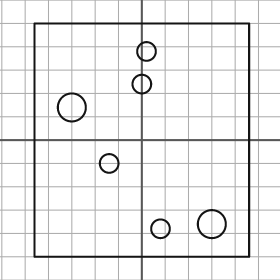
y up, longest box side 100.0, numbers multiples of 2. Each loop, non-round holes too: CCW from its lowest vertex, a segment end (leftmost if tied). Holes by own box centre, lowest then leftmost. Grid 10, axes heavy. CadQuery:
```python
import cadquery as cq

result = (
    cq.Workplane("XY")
    .moveTo(-46.0, -50.0)
    .lineTo(46.0, -50.0)
    .lineTo(46.0, 50.0)
    .lineTo(-46.0, 50.0)
    .close()
    .moveTo(8.0, -38.0)
    .circle(4.0)
    .moveTo(30.0, -36.0)
    .circle(6.0)
    .moveTo(-14.0, -10.0)
    .circle(4.0)
    .moveTo(-30.0, 14.0)
    .circle(6.0)
    .moveTo(0.0, 24.0)
    .circle(4.0)
    .moveTo(2.0, 38.0)
    .circle(4.0)
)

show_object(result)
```